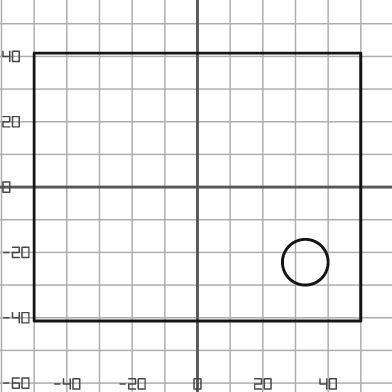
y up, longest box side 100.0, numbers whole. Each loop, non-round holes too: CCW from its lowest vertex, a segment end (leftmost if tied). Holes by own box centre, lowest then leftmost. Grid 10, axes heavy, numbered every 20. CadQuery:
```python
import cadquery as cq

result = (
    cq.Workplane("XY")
    .moveTo(-50.0, -41.0)
    .lineTo(50.0, -41.0)
    .lineTo(50.0, 41.0)
    .lineTo(-50.0, 41.0)
    .close()
    .moveTo(33.0, -23.0)
    .circle(7.0)
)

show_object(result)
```